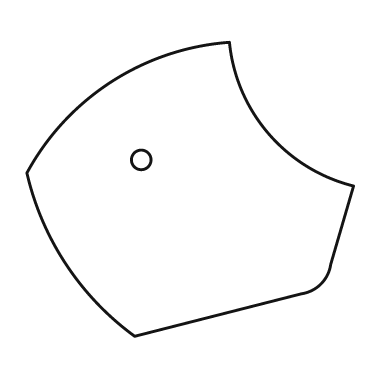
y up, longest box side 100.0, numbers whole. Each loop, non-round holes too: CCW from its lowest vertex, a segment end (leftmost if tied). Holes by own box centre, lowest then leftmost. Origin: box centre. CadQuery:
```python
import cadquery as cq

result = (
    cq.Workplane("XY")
    .moveTo(-17.0, -45.0)
    .lineTo(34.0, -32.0)
    .threePointArc((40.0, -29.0), (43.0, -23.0))
    .lineTo(50.0, 1.0)
    .threePointArc((24.0, 17.0), (12.0, 45.0))
    .threePointArc((-24.0, 33.0), (-50.0, 5.0))
    .threePointArc((-38.0, -23.0), (-17.0, -45.0))
    .close()
    .moveTo(-15.0, 9.0)
    .circle(3.0)
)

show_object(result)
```